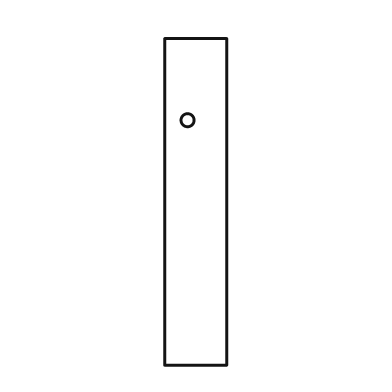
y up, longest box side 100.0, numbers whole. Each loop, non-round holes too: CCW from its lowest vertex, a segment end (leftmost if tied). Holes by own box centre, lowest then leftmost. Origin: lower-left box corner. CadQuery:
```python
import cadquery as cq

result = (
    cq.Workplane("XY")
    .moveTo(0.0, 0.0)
    .lineTo(19.0, 0.0)
    .lineTo(19.0, 100.0)
    .lineTo(0.0, 100.0)
    .close()
    .moveTo(7.0, 75.0)
    .circle(2.0)
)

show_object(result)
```